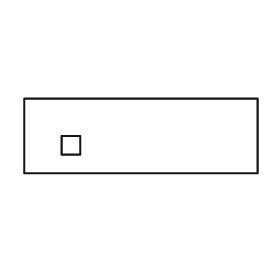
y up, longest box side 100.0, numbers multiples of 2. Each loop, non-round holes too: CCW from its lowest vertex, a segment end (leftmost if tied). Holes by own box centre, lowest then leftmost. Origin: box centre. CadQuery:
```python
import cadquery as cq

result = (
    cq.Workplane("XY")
    .moveTo(-50.0, -16.0)
    .lineTo(50.0, -16.0)
    .lineTo(50.0, 16.0)
    .lineTo(-50.0, 16.0)
    .close()
    .moveTo(-34.0, -8.0)
    .lineTo(-26.0, -8.0)
    .lineTo(-26.0, 0.0)
    .lineTo(-34.0, 0.0)
    .close()
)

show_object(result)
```